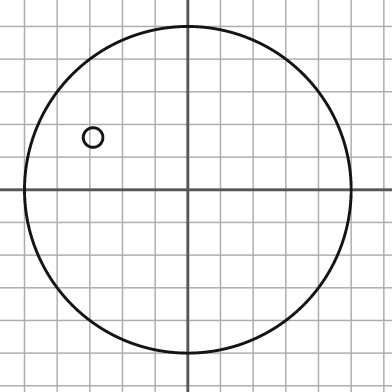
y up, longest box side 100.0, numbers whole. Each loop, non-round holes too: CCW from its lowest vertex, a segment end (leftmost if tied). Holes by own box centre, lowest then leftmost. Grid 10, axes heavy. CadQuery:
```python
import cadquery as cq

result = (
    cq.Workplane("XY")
    .moveTo(0.0, 0.0)
    .circle(50.0)
    .moveTo(-29.0, 16.0)
    .circle(3.0)
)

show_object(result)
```